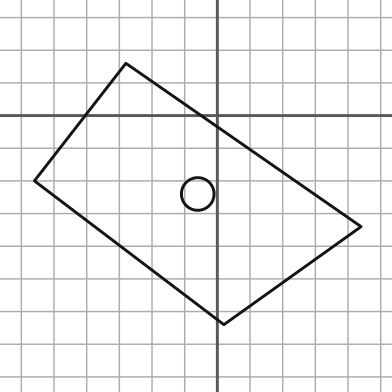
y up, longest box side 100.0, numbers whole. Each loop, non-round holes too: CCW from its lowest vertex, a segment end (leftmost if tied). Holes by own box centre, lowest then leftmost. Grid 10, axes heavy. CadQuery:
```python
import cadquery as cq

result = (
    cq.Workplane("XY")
    .moveTo(2.0, -64.0)
    .lineTo(44.0, -34.0)
    .lineTo(-28.0, 16.0)
    .lineTo(-56.0, -20.0)
    .close()
    .moveTo(-6.0, -24.0)
    .circle(5.0)
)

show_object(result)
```